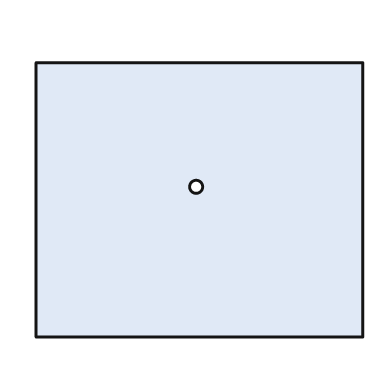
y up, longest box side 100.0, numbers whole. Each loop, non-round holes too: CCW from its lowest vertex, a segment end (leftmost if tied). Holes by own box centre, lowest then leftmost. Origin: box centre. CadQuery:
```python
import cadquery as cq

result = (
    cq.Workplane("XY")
    .moveTo(-50.0, -42.0)
    .lineTo(50.0, -42.0)
    .lineTo(50.0, 42.0)
    .lineTo(-50.0, 42.0)
    .close()
    .moveTo(-1.0, 4.0)
    .circle(2.0)
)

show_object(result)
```